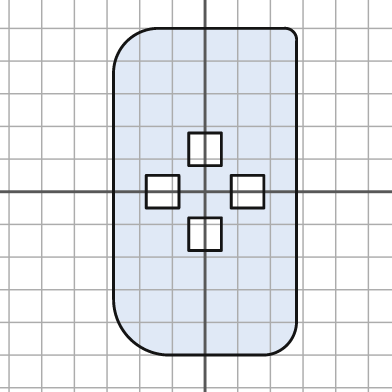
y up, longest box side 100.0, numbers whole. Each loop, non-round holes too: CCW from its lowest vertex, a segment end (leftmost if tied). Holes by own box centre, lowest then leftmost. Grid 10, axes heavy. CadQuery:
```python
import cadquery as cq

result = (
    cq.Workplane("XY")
    .moveTo(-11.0, -50.0)
    .lineTo(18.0, -50.0)
    .threePointArc((25.0, -47.0), (28.0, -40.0))
    .lineTo(28.0, 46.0)
    .threePointArc((27.0, 49.0), (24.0, 50.0))
    .lineTo(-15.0, 50.0)
    .threePointArc((-24.0, 46.0), (-28.0, 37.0))
    .lineTo(-28.0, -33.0)
    .threePointArc((-23.0, -45.0), (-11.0, -50.0))
    .close()
    .moveTo(-5.0, -18.0)
    .lineTo(5.0, -18.0)
    .lineTo(5.0, -8.0)
    .lineTo(-5.0, -8.0)
    .close()
    .moveTo(-18.0, -5.0)
    .lineTo(-8.0, -5.0)
    .lineTo(-8.0, 5.0)
    .lineTo(-18.0, 5.0)
    .close()
    .moveTo(8.0, -5.0)
    .lineTo(18.0, -5.0)
    .lineTo(18.0, 5.0)
    .lineTo(8.0, 5.0)
    .close()
    .moveTo(-5.0, 8.0)
    .lineTo(5.0, 8.0)
    .lineTo(5.0, 18.0)
    .lineTo(-5.0, 18.0)
    .close()
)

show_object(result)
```